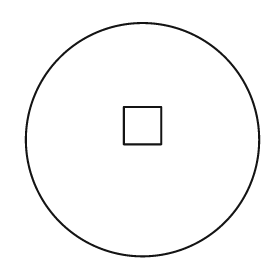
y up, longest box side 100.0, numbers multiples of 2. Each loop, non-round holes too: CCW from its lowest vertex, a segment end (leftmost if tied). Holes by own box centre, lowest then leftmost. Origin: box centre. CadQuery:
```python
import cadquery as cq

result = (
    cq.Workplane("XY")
    .moveTo(0.0, 0.0)
    .circle(50.0)
    .moveTo(-8.0, -2.0)
    .lineTo(8.0, -2.0)
    .lineTo(8.0, 14.0)
    .lineTo(-8.0, 14.0)
    .close()
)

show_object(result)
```